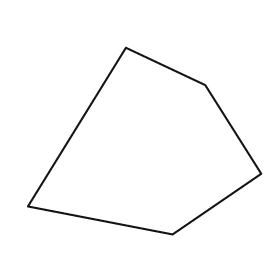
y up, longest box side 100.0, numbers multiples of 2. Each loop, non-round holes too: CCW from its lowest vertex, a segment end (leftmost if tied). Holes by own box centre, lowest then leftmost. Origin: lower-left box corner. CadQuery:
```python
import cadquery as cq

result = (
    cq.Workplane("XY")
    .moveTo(62.0, 0.0)
    .lineTo(100.0, 26.0)
    .lineTo(76.0, 64.0)
    .lineTo(42.0, 80.0)
    .lineTo(0.0, 12.0)
    .close()
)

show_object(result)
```